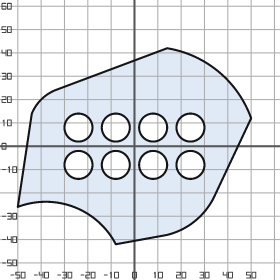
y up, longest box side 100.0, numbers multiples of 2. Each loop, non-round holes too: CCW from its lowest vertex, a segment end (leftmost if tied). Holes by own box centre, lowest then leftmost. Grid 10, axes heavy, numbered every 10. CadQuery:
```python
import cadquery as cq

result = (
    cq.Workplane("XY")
    .moveTo(-8.0, -42.0)
    .lineTo(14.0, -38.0)
    .threePointArc((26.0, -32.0), (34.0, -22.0))
    .lineTo(50.0, 12.0)
    .threePointArc((36.0, 32.0), (14.0, 42.0))
    .lineTo(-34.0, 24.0)
    .threePointArc((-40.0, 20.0), (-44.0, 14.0))
    .lineTo(-50.0, -26.0)
    .threePointArc((-26.0, -26.0), (-8.0, -42.0))
    .close()
    .moveTo(-24.0, -8.0)
    .circle(6.0)
    .moveTo(-8.0, -8.0)
    .circle(6.0)
    .moveTo(8.0, -8.0)
    .circle(6.0)
    .moveTo(24.0, -8.0)
    .circle(6.0)
    .moveTo(-24.0, 8.0)
    .circle(6.0)
    .moveTo(-8.0, 8.0)
    .circle(6.0)
    .moveTo(8.0, 8.0)
    .circle(6.0)
    .moveTo(24.0, 8.0)
    .circle(6.0)
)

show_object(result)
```